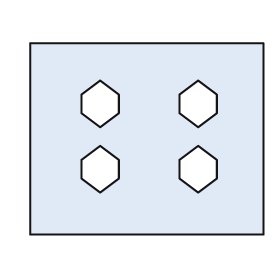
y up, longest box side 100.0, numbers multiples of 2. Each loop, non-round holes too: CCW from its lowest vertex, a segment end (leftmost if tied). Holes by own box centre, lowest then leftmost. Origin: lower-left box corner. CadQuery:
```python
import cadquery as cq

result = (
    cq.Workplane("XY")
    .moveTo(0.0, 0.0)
    .lineTo(100.0, 0.0)
    .lineTo(100.0, 82.0)
    .lineTo(0.0, 82.0)
    .close()
    .moveTo(30.0, 18.0)
    .lineTo(38.0, 24.0)
    .lineTo(38.0, 32.0)
    .lineTo(30.0, 38.0)
    .lineTo(22.0, 32.0)
    .lineTo(22.0, 24.0)
    .close()
    .moveTo(72.0, 18.0)
    .lineTo(80.0, 24.0)
    .lineTo(80.0, 32.0)
    .lineTo(72.0, 38.0)
    .lineTo(64.0, 32.0)
    .lineTo(64.0, 24.0)
    .close()
    .moveTo(30.0, 46.0)
    .lineTo(38.0, 52.0)
    .lineTo(38.0, 60.0)
    .lineTo(30.0, 66.0)
    .lineTo(22.0, 60.0)
    .lineTo(22.0, 52.0)
    .close()
    .moveTo(72.0, 46.0)
    .lineTo(80.0, 52.0)
    .lineTo(80.0, 60.0)
    .lineTo(72.0, 66.0)
    .lineTo(64.0, 60.0)
    .lineTo(64.0, 52.0)
    .close()
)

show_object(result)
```